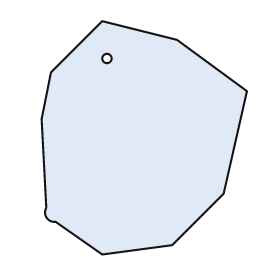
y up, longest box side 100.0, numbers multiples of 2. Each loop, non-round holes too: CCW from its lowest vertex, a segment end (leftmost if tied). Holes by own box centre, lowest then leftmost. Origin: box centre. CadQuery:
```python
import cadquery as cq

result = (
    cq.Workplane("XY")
    .moveTo(-18.0, -50.0)
    .lineTo(12.0, -46.0)
    .lineTo(34.0, -24.0)
    .lineTo(44.0, 20.0)
    .lineTo(14.0, 42.0)
    .lineTo(-18.0, 50.0)
    .lineTo(-40.0, 28.0)
    .lineTo(-44.0, 8.0)
    .lineTo(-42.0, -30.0)
    .threePointArc((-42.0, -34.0), (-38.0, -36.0))
    .close()
    .moveTo(-16.0, 34.0)
    .circle(2.0)
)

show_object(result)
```